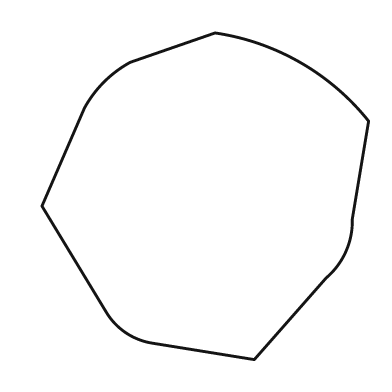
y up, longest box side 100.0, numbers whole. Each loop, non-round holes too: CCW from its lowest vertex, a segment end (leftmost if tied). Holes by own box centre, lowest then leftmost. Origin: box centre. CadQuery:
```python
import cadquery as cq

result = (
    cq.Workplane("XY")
    .moveTo(15.0, -50.0)
    .lineTo(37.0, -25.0)
    .threePointArc((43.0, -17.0), (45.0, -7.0))
    .lineTo(50.0, 23.0)
    .threePointArc((29.0, 41.0), (3.0, 50.0))
    .lineTo(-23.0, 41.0)
    .threePointArc((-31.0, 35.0), (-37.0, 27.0))
    .lineTo(-50.0, -3.0)
    .lineTo(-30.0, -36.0)
    .threePointArc((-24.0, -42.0), (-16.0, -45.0))
    .close()
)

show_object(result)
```